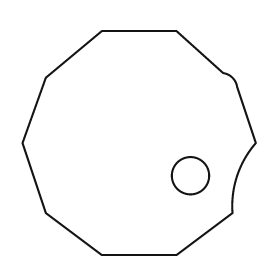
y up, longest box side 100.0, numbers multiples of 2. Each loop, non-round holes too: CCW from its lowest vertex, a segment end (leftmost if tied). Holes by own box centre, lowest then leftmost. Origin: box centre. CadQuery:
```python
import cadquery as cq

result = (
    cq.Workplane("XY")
    .moveTo(-16.0, -48.0)
    .lineTo(16.0, -48.0)
    .lineTo(40.0, -30.0)
    .threePointArc((42.0, -14.0), (50.0, 0.0))
    .lineTo(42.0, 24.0)
    .threePointArc((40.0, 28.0), (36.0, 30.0))
    .lineTo(16.0, 48.0)
    .lineTo(-16.0, 48.0)
    .lineTo(-40.0, 28.0)
    .lineTo(-50.0, 0.0)
    .lineTo(-40.0, -30.0)
    .close()
    .moveTo(22.0, -14.0)
    .circle(8.0)
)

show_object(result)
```